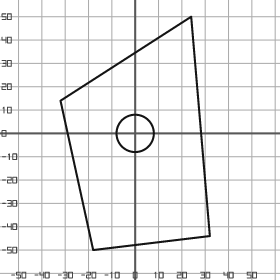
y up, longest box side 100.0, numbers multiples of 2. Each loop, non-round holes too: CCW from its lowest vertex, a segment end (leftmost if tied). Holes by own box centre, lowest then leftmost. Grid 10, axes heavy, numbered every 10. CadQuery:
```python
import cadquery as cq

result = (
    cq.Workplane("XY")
    .moveTo(-18.0, -50.0)
    .lineTo(32.0, -44.0)
    .lineTo(24.0, 50.0)
    .lineTo(-32.0, 14.0)
    .close()
    .moveTo(0.0, 0.0)
    .circle(8.0)
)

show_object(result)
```